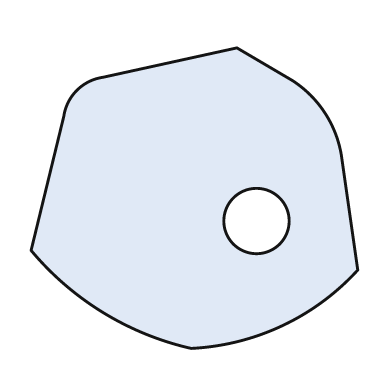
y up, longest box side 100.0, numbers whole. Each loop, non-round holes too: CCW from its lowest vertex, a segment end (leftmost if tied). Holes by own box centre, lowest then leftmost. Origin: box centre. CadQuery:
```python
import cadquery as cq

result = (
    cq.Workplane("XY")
    .moveTo(-1.0, -46.0)
    .threePointArc((27.0, -39.0), (50.0, -22.0))
    .lineTo(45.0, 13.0)
    .threePointArc((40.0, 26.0), (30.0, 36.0))
    .lineTo(13.0, 46.0)
    .lineTo(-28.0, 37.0)
    .threePointArc((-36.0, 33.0), (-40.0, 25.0))
    .lineTo(-50.0, -16.0)
    .threePointArc((-28.0, -35.0), (-1.0, -46.0))
    .close()
    .moveTo(19.0, -7.0)
    .circle(10.0)
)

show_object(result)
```